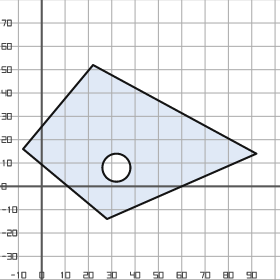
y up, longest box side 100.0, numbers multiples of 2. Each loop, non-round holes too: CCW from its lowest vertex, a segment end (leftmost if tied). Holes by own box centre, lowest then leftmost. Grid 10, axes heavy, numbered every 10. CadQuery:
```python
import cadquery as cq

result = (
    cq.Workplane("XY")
    .moveTo(28.0, -14.0)
    .lineTo(92.0, 14.0)
    .lineTo(22.0, 52.0)
    .lineTo(-8.0, 16.0)
    .close()
    .moveTo(32.0, 8.0)
    .circle(6.0)
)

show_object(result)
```